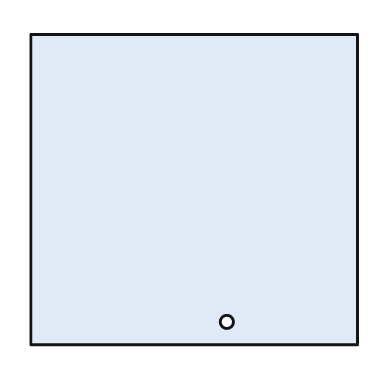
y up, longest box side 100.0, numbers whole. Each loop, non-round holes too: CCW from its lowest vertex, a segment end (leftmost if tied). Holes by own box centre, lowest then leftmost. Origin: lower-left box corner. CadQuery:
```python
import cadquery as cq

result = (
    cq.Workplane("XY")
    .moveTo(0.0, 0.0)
    .lineTo(100.0, 0.0)
    .lineTo(100.0, 95.0)
    .lineTo(0.0, 95.0)
    .close()
    .moveTo(60.0, 7.0)
    .circle(2.0)
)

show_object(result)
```